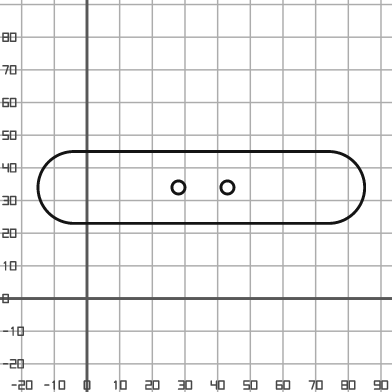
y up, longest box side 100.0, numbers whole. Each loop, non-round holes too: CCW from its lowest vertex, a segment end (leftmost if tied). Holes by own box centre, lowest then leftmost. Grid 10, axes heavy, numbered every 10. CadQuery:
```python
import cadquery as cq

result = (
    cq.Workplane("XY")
    .moveTo(-4.0, 23.0)
    .lineTo(74.0, 23.0)
    .threePointArc((85.0, 34.0), (74.0, 45.0))
    .lineTo(-4.0, 45.0)
    .threePointArc((-15.0, 34.0), (-4.0, 23.0))
    .close()
    .moveTo(28.0, 34.0)
    .circle(2.0)
    .moveTo(43.0, 34.0)
    .circle(2.0)
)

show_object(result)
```